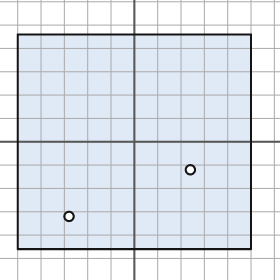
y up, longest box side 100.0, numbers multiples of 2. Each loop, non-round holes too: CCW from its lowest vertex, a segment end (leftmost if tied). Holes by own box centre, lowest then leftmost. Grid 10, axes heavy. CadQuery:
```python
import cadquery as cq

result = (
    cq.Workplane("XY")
    .moveTo(-50.0, -46.0)
    .lineTo(50.0, -46.0)
    .lineTo(50.0, 46.0)
    .lineTo(-50.0, 46.0)
    .close()
    .moveTo(-28.0, -32.0)
    .circle(2.0)
    .moveTo(24.0, -12.0)
    .circle(2.0)
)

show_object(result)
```